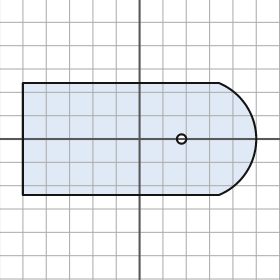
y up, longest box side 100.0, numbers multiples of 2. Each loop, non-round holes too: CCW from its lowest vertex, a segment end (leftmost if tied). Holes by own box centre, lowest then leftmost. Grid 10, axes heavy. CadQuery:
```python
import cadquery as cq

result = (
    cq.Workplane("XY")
    .moveTo(-50.0, -24.0)
    .lineTo(34.0, -24.0)
    .threePointArc((50.0, 0.0), (34.0, 24.0))
    .lineTo(-50.0, 24.0)
    .close()
    .moveTo(18.0, 0.0)
    .circle(2.0)
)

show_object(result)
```